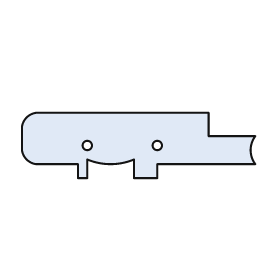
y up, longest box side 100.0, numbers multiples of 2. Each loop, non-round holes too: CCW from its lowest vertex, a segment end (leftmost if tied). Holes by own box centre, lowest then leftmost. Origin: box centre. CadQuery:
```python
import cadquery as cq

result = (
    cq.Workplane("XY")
    .moveTo(-26.0, -14.0)
    .lineTo(-22.0, -14.0)
    .lineTo(-22.0, -6.0)
    .threePointArc((-12.0, -8.0), (-2.0, -6.0))
    .lineTo(-2.0, -14.0)
    .lineTo(8.0, -14.0)
    .lineTo(8.0, -8.0)
    .lineTo(50.0, -8.0)
    .threePointArc((48.0, -2.0), (50.0, 4.0))
    .lineTo(30.0, 4.0)
    .lineTo(30.0, 14.0)
    .lineTo(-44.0, 14.0)
    .threePointArc((-48.0, 12.0), (-50.0, 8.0))
    .lineTo(-50.0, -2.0)
    .threePointArc((-48.0, -6.0), (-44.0, -8.0))
    .lineTo(-26.0, -8.0)
    .close()
    .moveTo(-22.0, 0.0)
    .circle(2.0)
    .moveTo(8.0, 0.0)
    .circle(2.0)
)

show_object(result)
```